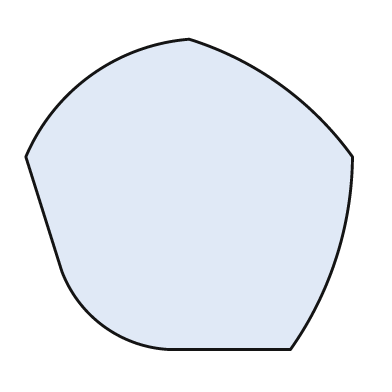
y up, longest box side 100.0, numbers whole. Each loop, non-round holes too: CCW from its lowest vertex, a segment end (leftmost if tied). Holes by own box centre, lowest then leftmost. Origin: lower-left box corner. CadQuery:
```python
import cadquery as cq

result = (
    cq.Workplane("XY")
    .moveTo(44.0, 0.0)
    .lineTo(81.0, 0.0)
    .threePointArc((95.0, 28.0), (100.0, 59.0))
    .threePointArc((78.0, 81.0), (50.0, 95.0))
    .threePointArc((20.0, 84.0), (0.0, 59.0))
    .lineTo(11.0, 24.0)
    .threePointArc((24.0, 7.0), (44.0, 0.0))
    .close()
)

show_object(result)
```